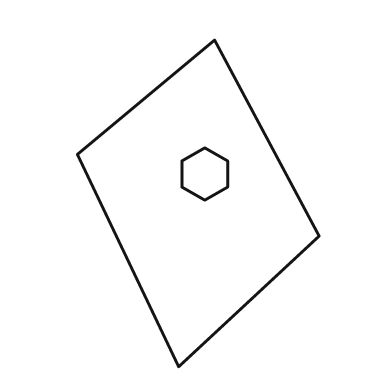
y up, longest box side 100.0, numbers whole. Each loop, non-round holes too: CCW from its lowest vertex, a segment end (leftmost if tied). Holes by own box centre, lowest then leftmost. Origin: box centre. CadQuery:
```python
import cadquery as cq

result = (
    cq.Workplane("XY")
    .moveTo(-6.0, -50.0)
    .lineTo(37.0, -10.0)
    .lineTo(5.0, 50.0)
    .lineTo(-37.0, 15.0)
    .close()
    .moveTo(2.0, 1.0)
    .lineTo(9.0, 5.0)
    .lineTo(9.0, 13.0)
    .lineTo(2.0, 17.0)
    .lineTo(-5.0, 13.0)
    .lineTo(-5.0, 5.0)
    .close()
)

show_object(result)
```